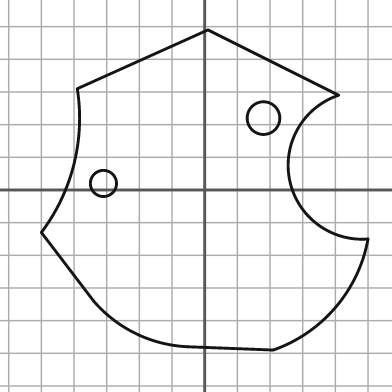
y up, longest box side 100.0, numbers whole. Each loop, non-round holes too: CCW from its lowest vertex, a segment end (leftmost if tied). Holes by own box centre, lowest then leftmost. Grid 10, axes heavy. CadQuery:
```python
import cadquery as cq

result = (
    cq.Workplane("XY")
    .moveTo(21.0, -49.0)
    .threePointArc((40.0, -36.0), (50.0, -15.0))
    .threePointArc((26.0, 3.0), (41.0, 29.0))
    .lineTo(1.0, 49.0)
    .lineTo(-39.0, 31.0)
    .threePointArc((-40.0, 8.0), (-50.0, -13.0))
    .lineTo(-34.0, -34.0)
    .threePointArc((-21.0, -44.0), (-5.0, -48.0))
    .close()
    .moveTo(-31.0, 2.0)
    .circle(4.0)
    .moveTo(18.0, 22.0)
    .circle(5.0)
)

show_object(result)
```